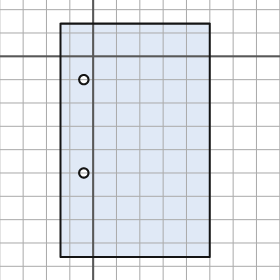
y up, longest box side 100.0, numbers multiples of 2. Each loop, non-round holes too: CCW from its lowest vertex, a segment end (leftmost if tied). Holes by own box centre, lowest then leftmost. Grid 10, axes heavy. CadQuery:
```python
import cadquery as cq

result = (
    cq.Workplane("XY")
    .moveTo(-14.0, -86.0)
    .lineTo(50.0, -86.0)
    .lineTo(50.0, 14.0)
    .lineTo(-14.0, 14.0)
    .close()
    .moveTo(-4.0, -50.0)
    .circle(2.0)
    .moveTo(-4.0, -10.0)
    .circle(2.0)
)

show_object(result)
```